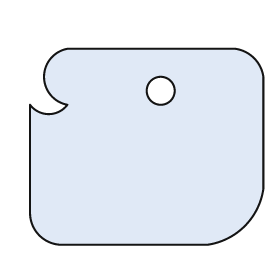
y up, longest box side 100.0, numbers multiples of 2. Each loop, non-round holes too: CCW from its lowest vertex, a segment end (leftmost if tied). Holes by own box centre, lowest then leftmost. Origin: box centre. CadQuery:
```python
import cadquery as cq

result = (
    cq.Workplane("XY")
    .moveTo(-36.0, -42.0)
    .lineTo(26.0, -42.0)
    .threePointArc((42.0, -34.0), (50.0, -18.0))
    .lineTo(50.0, 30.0)
    .threePointArc((46.0, 38.0), (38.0, 42.0))
    .lineTo(-34.0, 42.0)
    .threePointArc((-44.0, 30.0), (-34.0, 18.0))
    .threePointArc((-42.0, 14.0), (-50.0, 18.0))
    .lineTo(-50.0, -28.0)
    .threePointArc((-46.0, -38.0), (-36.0, -42.0))
    .close()
    .moveTo(6.0, 24.0)
    .circle(6.0)
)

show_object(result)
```